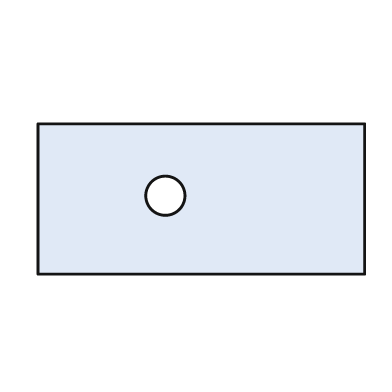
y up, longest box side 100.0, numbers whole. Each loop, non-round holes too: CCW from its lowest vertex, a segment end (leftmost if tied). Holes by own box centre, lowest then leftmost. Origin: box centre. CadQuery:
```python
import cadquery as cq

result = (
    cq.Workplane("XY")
    .moveTo(-50.0, -23.0)
    .lineTo(50.0, -23.0)
    .lineTo(50.0, 23.0)
    .lineTo(-50.0, 23.0)
    .close()
    .moveTo(-11.0, 1.0)
    .circle(6.0)
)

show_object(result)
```